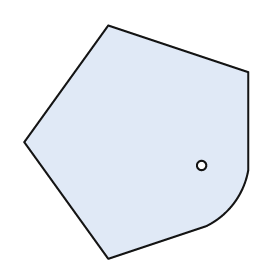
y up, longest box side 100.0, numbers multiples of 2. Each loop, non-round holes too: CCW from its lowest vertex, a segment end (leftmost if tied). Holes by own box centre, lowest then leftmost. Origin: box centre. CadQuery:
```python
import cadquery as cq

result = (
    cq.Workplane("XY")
    .moveTo(-12.0, -50.0)
    .lineTo(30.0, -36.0)
    .threePointArc((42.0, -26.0), (48.0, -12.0))
    .lineTo(48.0, 30.0)
    .lineTo(-12.0, 50.0)
    .lineTo(-48.0, 0.0)
    .close()
    .moveTo(28.0, -10.0)
    .circle(2.0)
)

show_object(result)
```